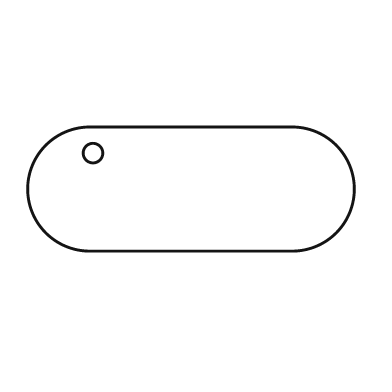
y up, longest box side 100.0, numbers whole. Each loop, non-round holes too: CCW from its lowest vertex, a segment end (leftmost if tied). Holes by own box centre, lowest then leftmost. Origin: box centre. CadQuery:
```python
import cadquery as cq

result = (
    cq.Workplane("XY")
    .moveTo(-31.0, -19.0)
    .lineTo(31.0, -19.0)
    .threePointArc((50.0, 0.0), (31.0, 19.0))
    .lineTo(-31.0, 19.0)
    .threePointArc((-50.0, 0.0), (-31.0, -19.0))
    .close()
    .moveTo(-30.0, 11.0)
    .circle(3.0)
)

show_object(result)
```